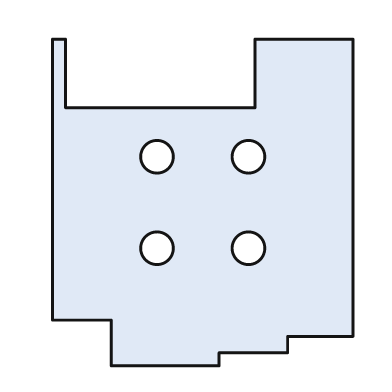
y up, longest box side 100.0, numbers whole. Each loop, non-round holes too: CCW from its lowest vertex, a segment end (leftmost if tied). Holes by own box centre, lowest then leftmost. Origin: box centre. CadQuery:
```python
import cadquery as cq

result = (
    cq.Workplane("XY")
    .moveTo(-28.0, -50.0)
    .lineTo(5.0, -50.0)
    .lineTo(5.0, -46.0)
    .lineTo(26.0, -46.0)
    .lineTo(26.0, -41.0)
    .lineTo(46.0, -41.0)
    .lineTo(46.0, 50.0)
    .lineTo(16.0, 50.0)
    .lineTo(16.0, 29.0)
    .lineTo(-42.0, 29.0)
    .lineTo(-42.0, 50.0)
    .lineTo(-46.0, 50.0)
    .lineTo(-46.0, -36.0)
    .lineTo(-28.0, -36.0)
    .close()
    .moveTo(-14.0, -14.0)
    .circle(5.0)
    .moveTo(14.0, -14.0)
    .circle(5.0)
    .moveTo(-14.0, 14.0)
    .circle(5.0)
    .moveTo(14.0, 14.0)
    .circle(5.0)
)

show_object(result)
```